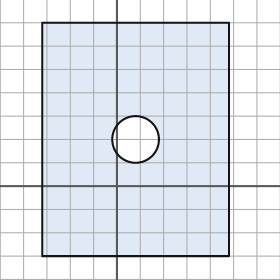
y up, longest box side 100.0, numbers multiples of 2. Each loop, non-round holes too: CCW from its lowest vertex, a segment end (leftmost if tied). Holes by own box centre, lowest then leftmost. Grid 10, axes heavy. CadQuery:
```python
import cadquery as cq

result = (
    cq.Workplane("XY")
    .moveTo(-32.0, -30.0)
    .lineTo(48.0, -30.0)
    .lineTo(48.0, 70.0)
    .lineTo(-32.0, 70.0)
    .close()
    .moveTo(8.0, 20.0)
    .circle(10.0)
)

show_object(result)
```